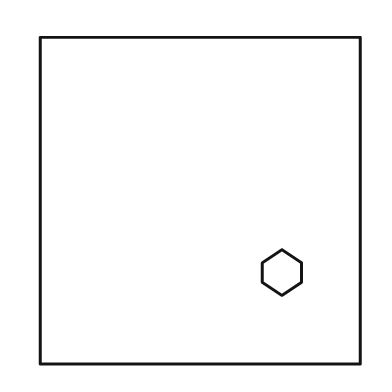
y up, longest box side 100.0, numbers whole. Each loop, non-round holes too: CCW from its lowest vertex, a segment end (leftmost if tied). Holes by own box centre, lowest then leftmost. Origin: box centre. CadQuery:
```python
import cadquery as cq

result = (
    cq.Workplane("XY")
    .moveTo(-49.0, -50.0)
    .lineTo(49.0, -50.0)
    .lineTo(49.0, 50.0)
    .lineTo(-49.0, 50.0)
    .close()
    .moveTo(25.0, -29.0)
    .lineTo(31.0, -25.0)
    .lineTo(31.0, -19.0)
    .lineTo(25.0, -15.0)
    .lineTo(19.0, -19.0)
    .lineTo(19.0, -25.0)
    .close()
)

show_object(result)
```